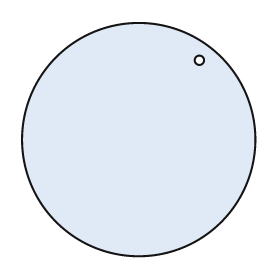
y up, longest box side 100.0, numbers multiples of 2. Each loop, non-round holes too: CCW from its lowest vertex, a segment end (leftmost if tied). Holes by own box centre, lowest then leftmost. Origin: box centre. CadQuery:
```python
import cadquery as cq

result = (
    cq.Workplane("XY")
    .moveTo(0.0, 0.0)
    .circle(50.0)
    .moveTo(26.0, 34.0)
    .circle(2.0)
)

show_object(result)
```